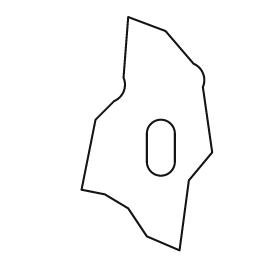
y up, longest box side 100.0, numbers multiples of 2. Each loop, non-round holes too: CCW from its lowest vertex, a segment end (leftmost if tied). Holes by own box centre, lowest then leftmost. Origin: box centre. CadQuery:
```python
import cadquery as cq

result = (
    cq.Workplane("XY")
    .moveTo(14.0, -50.0)
    .lineTo(18.0, -20.0)
    .lineTo(28.0, -8.0)
    .lineTo(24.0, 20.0)
    .threePointArc((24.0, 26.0), (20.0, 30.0))
    .lineTo(8.0, 44.0)
    .lineTo(-8.0, 50.0)
    .lineTo(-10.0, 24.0)
    .threePointArc((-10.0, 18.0), (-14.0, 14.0))
    .lineTo(-22.0, 6.0)
    .lineTo(-28.0, -24.0)
    .lineTo(-18.0, -26.0)
    .lineTo(-8.0, -32.0)
    .lineTo(0.0, -44.0)
    .close()
    .moveTo(0.0, -12.0)
    .threePointArc((6.0, -18.0), (12.0, -12.0))
    .lineTo(12.0, 0.0)
    .threePointArc((6.0, 6.0), (0.0, 0.0))
    .close()
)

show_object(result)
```